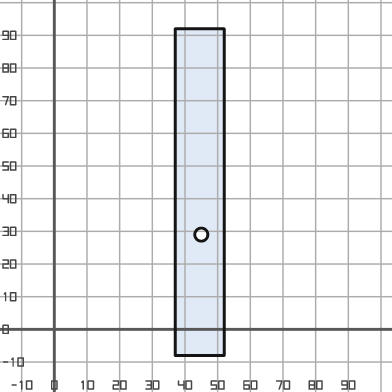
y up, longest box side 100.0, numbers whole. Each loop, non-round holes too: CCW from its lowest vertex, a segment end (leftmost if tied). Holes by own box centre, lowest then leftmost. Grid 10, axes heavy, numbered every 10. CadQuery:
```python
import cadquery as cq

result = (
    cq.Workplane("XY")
    .moveTo(37.0, -8.0)
    .lineTo(52.0, -8.0)
    .lineTo(52.0, 92.0)
    .lineTo(37.0, 92.0)
    .close()
    .moveTo(45.0, 29.0)
    .circle(2.0)
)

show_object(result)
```